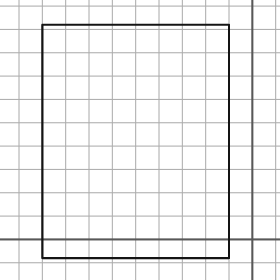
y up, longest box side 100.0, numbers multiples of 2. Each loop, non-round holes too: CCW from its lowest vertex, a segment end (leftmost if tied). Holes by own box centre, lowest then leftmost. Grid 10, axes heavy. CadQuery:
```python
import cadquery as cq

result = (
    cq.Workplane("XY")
    .moveTo(-90.0, -8.0)
    .lineTo(-10.0, -8.0)
    .lineTo(-10.0, 92.0)
    .lineTo(-90.0, 92.0)
    .close()
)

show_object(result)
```